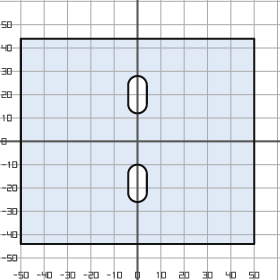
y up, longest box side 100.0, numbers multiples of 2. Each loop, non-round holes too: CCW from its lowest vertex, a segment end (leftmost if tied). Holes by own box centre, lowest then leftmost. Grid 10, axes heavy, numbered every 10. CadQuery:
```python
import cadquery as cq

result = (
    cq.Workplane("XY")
    .moveTo(-50.0, -44.0)
    .lineTo(50.0, -44.0)
    .lineTo(50.0, 44.0)
    .lineTo(-50.0, 44.0)
    .close()
    .moveTo(-4.0, -22.0)
    .threePointArc((0.0, -26.0), (4.0, -22.0))
    .lineTo(4.0, -14.0)
    .threePointArc((0.0, -10.0), (-4.0, -14.0))
    .close()
    .moveTo(-4.0, 16.0)
    .threePointArc((0.0, 12.0), (4.0, 16.0))
    .lineTo(4.0, 24.0)
    .threePointArc((0.0, 28.0), (-4.0, 24.0))
    .close()
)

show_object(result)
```